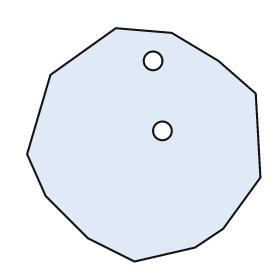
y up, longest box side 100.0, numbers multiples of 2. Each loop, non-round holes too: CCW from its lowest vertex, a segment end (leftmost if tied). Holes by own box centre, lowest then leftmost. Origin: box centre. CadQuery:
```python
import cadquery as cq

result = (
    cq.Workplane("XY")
    .moveTo(-4.0, -50.0)
    .lineTo(22.0, -44.0)
    .lineTo(34.0, -36.0)
    .lineTo(50.0, -14.0)
    .lineTo(48.0, 22.0)
    .lineTo(32.0, 36.0)
    .lineTo(12.0, 48.0)
    .lineTo(-12.0, 50.0)
    .lineTo(-40.0, 30.0)
    .lineTo(-50.0, -4.0)
    .lineTo(-42.0, -22.0)
    .lineTo(-24.0, -40.0)
    .close()
    .moveTo(8.0, 6.0)
    .circle(4.0)
    .moveTo(4.0, 36.0)
    .circle(4.0)
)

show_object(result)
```